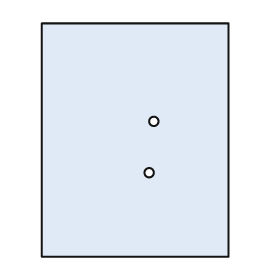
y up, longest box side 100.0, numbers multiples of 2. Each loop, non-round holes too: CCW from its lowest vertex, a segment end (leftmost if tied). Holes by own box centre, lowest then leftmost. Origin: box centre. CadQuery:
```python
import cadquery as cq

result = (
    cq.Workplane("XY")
    .moveTo(-40.0, -50.0)
    .lineTo(40.0, -50.0)
    .lineTo(40.0, 50.0)
    .lineTo(-40.0, 50.0)
    .close()
    .moveTo(6.0, -14.0)
    .circle(2.0)
    .moveTo(8.0, 8.0)
    .circle(2.0)
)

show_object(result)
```